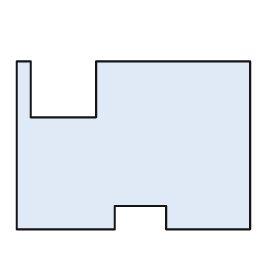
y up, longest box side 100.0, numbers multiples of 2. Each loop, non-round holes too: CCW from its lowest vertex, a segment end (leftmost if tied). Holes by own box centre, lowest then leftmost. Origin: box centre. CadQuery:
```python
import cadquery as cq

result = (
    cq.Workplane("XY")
    .moveTo(-50.0, -36.0)
    .lineTo(-8.0, -36.0)
    .lineTo(-8.0, -26.0)
    .lineTo(14.0, -26.0)
    .lineTo(14.0, -36.0)
    .lineTo(50.0, -36.0)
    .lineTo(50.0, 36.0)
    .lineTo(-16.0, 36.0)
    .lineTo(-16.0, 12.0)
    .lineTo(-44.0, 12.0)
    .lineTo(-44.0, 36.0)
    .lineTo(-50.0, 36.0)
    .close()
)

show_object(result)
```